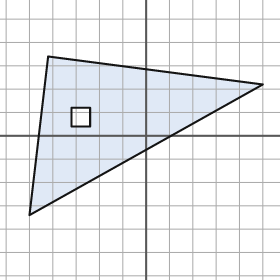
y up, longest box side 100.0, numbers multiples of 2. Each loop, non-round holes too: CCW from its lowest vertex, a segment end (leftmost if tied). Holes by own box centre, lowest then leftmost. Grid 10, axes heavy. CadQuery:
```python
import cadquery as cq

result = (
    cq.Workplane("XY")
    .moveTo(-50.0, -34.0)
    .lineTo(50.0, 22.0)
    .lineTo(-42.0, 34.0)
    .close()
    .moveTo(-32.0, 4.0)
    .lineTo(-24.0, 4.0)
    .lineTo(-24.0, 12.0)
    .lineTo(-32.0, 12.0)
    .close()
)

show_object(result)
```